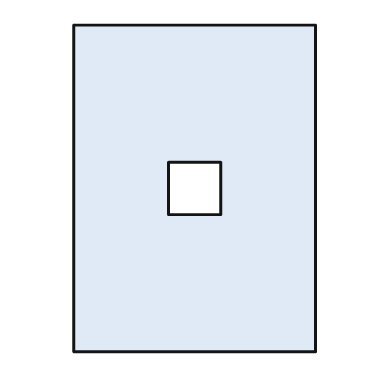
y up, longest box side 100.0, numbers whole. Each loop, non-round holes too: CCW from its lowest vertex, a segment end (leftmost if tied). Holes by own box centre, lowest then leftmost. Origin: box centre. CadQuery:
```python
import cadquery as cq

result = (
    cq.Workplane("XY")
    .moveTo(-37.0, -50.0)
    .lineTo(37.0, -50.0)
    .lineTo(37.0, 50.0)
    .lineTo(-37.0, 50.0)
    .close()
    .moveTo(-8.0, -8.0)
    .lineTo(8.0, -8.0)
    .lineTo(8.0, 8.0)
    .lineTo(-8.0, 8.0)
    .close()
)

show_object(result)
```